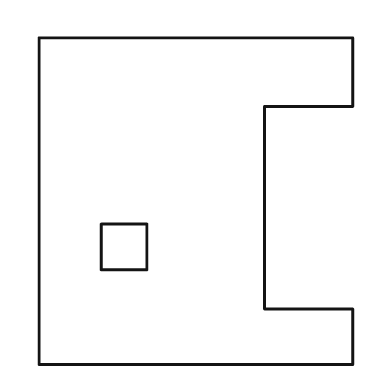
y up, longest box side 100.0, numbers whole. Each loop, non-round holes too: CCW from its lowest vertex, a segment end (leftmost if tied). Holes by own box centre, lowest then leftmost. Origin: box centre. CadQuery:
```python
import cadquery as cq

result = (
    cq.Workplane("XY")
    .moveTo(-48.0, -50.0)
    .lineTo(48.0, -50.0)
    .lineTo(48.0, -33.0)
    .lineTo(21.0, -33.0)
    .lineTo(21.0, 29.0)
    .lineTo(48.0, 29.0)
    .lineTo(48.0, 50.0)
    .lineTo(-48.0, 50.0)
    .close()
    .moveTo(-29.0, -21.0)
    .lineTo(-15.0, -21.0)
    .lineTo(-15.0, -7.0)
    .lineTo(-29.0, -7.0)
    .close()
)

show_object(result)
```